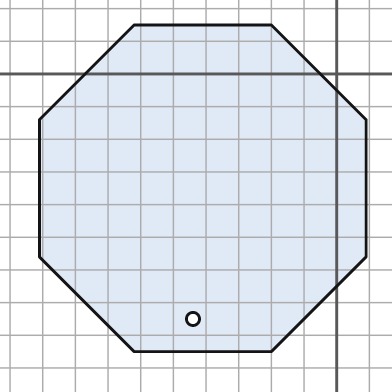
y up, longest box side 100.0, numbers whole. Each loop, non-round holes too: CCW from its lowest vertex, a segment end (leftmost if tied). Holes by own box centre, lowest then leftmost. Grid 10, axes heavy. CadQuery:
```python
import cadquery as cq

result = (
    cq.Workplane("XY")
    .moveTo(-62.0, -85.0)
    .lineTo(-20.0, -85.0)
    .lineTo(9.0, -56.0)
    .lineTo(9.0, -14.0)
    .lineTo(-20.0, 15.0)
    .lineTo(-62.0, 15.0)
    .lineTo(-91.0, -14.0)
    .lineTo(-91.0, -56.0)
    .close()
    .moveTo(-44.0, -75.0)
    .circle(2.0)
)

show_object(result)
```